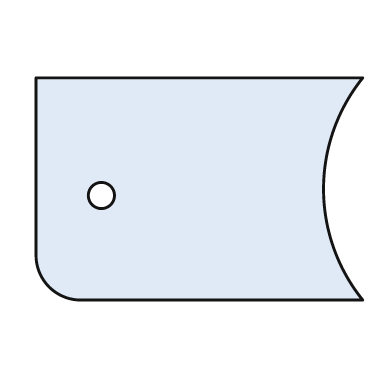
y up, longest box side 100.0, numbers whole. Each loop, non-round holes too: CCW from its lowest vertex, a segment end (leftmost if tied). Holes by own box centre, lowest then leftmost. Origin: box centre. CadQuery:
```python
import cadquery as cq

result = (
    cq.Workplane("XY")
    .moveTo(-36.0, -34.0)
    .lineTo(50.0, -34.0)
    .threePointArc((38.0, 0.0), (50.0, 34.0))
    .lineTo(-50.0, 34.0)
    .lineTo(-50.0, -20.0)
    .threePointArc((-46.0, -30.0), (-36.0, -34.0))
    .close()
    .moveTo(-30.0, -2.0)
    .circle(4.0)
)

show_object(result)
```